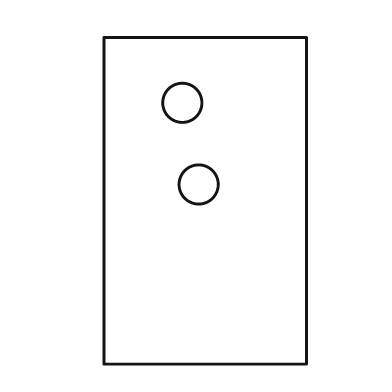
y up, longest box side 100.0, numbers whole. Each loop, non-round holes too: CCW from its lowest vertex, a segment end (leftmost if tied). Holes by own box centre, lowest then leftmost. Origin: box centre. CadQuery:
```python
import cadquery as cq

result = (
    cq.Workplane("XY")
    .moveTo(-31.0, -50.0)
    .lineTo(31.0, -50.0)
    .lineTo(31.0, 50.0)
    .lineTo(-31.0, 50.0)
    .close()
    .moveTo(-2.0, 5.0)
    .circle(6.0)
    .moveTo(-7.0, 30.0)
    .circle(6.0)
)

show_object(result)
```